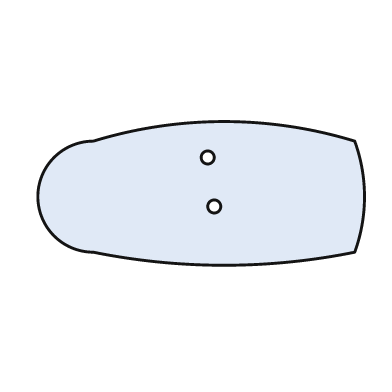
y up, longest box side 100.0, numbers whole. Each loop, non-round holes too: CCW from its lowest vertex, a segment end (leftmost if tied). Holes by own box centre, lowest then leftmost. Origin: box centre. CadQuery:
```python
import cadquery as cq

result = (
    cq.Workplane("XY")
    .moveTo(-33.0, -18.0)
    .threePointArc((7.0, -22.0), (47.0, -18.0))
    .threePointArc((50.0, -1.0), (47.0, 16.0))
    .threePointArc((7.0, 22.0), (-33.0, 16.0))
    .threePointArc((-50.0, -1.0), (-33.0, -18.0))
    .close()
    .moveTo(4.0, -4.0)
    .circle(2.0)
    .moveTo(2.0, 11.0)
    .circle(2.0)
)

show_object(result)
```